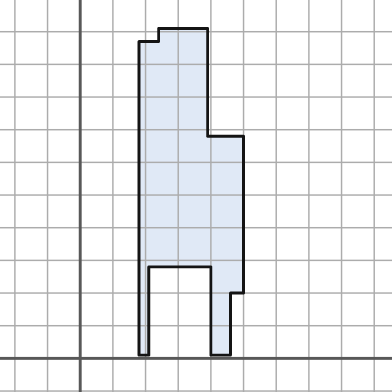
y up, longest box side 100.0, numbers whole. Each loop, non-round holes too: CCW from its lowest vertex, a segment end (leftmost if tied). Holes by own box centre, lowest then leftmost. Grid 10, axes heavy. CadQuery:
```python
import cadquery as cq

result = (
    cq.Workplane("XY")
    .moveTo(18.0, 1.0)
    .lineTo(21.0, 1.0)
    .lineTo(21.0, 28.0)
    .lineTo(40.0, 28.0)
    .lineTo(40.0, 1.0)
    .lineTo(46.0, 1.0)
    .lineTo(46.0, 20.0)
    .lineTo(50.0, 20.0)
    .lineTo(50.0, 68.0)
    .lineTo(39.0, 68.0)
    .lineTo(39.0, 101.0)
    .lineTo(24.0, 101.0)
    .lineTo(24.0, 97.0)
    .lineTo(18.0, 97.0)
    .close()
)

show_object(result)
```